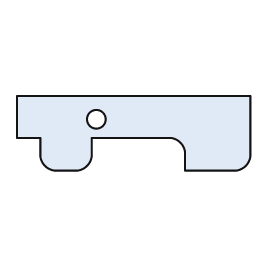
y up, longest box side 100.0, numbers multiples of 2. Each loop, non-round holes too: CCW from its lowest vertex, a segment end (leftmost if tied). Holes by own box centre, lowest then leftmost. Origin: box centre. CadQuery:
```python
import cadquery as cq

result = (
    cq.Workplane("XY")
    .moveTo(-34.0, -16.0)
    .lineTo(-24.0, -16.0)
    .threePointArc((-20.0, -14.0), (-18.0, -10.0))
    .lineTo(-18.0, -2.0)
    .lineTo(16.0, -2.0)
    .threePointArc((20.0, -4.0), (22.0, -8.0))
    .lineTo(22.0, -16.0)
    .lineTo(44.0, -16.0)
    .threePointArc((48.0, -14.0), (50.0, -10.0))
    .lineTo(50.0, 16.0)
    .lineTo(-50.0, 16.0)
    .lineTo(-50.0, -2.0)
    .lineTo(-40.0, -2.0)
    .lineTo(-40.0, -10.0)
    .threePointArc((-38.0, -14.0), (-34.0, -16.0))
    .close()
    .moveTo(-16.0, 6.0)
    .circle(4.0)
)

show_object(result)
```